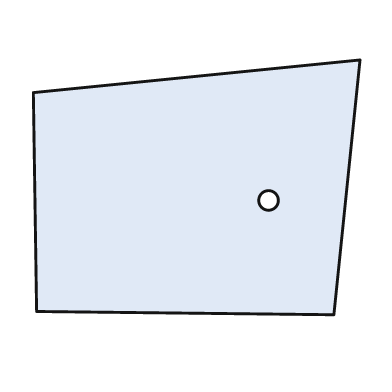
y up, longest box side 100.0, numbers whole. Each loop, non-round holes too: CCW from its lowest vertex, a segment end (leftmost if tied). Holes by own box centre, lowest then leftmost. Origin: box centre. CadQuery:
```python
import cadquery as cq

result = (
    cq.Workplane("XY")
    .moveTo(42.0, -39.0)
    .lineTo(50.0, 39.0)
    .lineTo(-50.0, 29.0)
    .lineTo(-49.0, -38.0)
    .close()
    .moveTo(22.0, -4.0)
    .circle(3.0)
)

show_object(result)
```